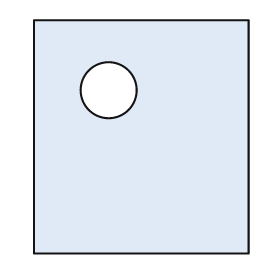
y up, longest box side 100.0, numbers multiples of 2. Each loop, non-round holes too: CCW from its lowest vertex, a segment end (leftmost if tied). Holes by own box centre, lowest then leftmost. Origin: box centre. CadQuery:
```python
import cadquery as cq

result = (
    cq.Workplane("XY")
    .moveTo(-46.0, -50.0)
    .lineTo(46.0, -50.0)
    .lineTo(46.0, 50.0)
    .lineTo(-46.0, 50.0)
    .close()
    .moveTo(-14.0, 20.0)
    .circle(12.0)
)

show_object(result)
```